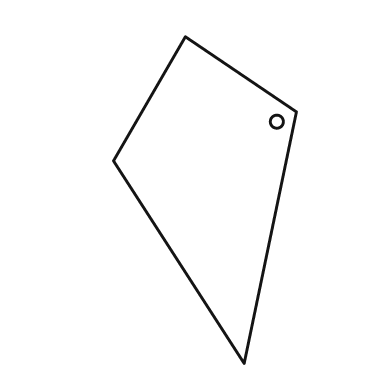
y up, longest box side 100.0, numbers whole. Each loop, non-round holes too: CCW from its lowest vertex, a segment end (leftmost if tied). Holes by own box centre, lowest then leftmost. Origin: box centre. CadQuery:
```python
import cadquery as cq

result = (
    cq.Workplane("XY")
    .moveTo(12.0, -50.0)
    .lineTo(28.0, 27.0)
    .lineTo(-6.0, 50.0)
    .lineTo(-28.0, 12.0)
    .close()
    .moveTo(22.0, 24.0)
    .circle(2.0)
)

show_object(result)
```